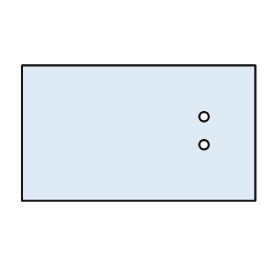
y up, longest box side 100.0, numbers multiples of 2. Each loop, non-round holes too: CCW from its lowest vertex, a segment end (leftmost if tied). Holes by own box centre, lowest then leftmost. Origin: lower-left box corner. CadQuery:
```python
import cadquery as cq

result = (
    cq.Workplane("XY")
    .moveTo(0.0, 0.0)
    .lineTo(100.0, 0.0)
    .lineTo(100.0, 58.0)
    .lineTo(0.0, 58.0)
    .close()
    .moveTo(78.0, 24.0)
    .circle(2.0)
    .moveTo(78.0, 36.0)
    .circle(2.0)
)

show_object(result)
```